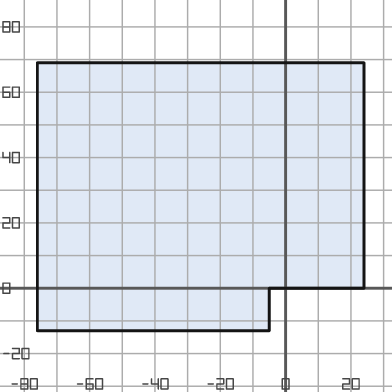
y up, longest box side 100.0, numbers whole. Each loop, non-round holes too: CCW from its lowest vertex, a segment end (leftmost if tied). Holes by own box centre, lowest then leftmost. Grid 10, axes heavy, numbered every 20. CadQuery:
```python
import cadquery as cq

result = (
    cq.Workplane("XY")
    .moveTo(-76.0, -13.0)
    .lineTo(-5.0, -13.0)
    .lineTo(-5.0, 0.0)
    .lineTo(24.0, 0.0)
    .lineTo(24.0, 69.0)
    .lineTo(-76.0, 69.0)
    .close()
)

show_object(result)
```